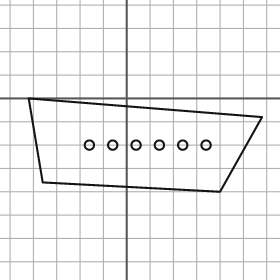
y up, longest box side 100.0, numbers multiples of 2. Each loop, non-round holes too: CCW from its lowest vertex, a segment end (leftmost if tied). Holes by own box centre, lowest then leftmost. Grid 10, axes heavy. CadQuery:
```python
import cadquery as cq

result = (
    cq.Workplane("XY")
    .moveTo(40.0, -40.0)
    .lineTo(58.0, -8.0)
    .lineTo(-42.0, 0.0)
    .lineTo(-36.0, -36.0)
    .close()
    .moveTo(-16.0, -20.0)
    .circle(2.0)
    .moveTo(-6.0, -20.0)
    .circle(2.0)
    .moveTo(4.0, -20.0)
    .circle(2.0)
    .moveTo(14.0, -20.0)
    .circle(2.0)
    .moveTo(24.0, -20.0)
    .circle(2.0)
    .moveTo(34.0, -20.0)
    .circle(2.0)
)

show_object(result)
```